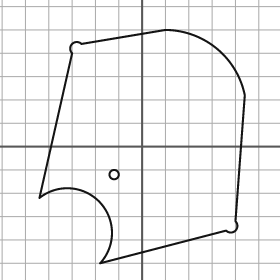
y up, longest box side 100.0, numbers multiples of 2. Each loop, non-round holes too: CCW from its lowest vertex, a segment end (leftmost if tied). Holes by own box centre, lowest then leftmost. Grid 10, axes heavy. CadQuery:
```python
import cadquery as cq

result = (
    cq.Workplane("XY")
    .moveTo(-18.0, -50.0)
    .lineTo(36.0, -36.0)
    .threePointArc((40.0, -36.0), (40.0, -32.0))
    .lineTo(44.0, 22.0)
    .threePointArc((32.0, 42.0), (10.0, 50.0))
    .lineTo(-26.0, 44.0)
    .threePointArc((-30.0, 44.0), (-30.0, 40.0))
    .lineTo(-44.0, -22.0)
    .threePointArc((-18.0, -24.0), (-18.0, -50.0))
    .close()
    .moveTo(-12.0, -12.0)
    .circle(2.0)
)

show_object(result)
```